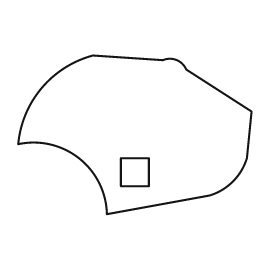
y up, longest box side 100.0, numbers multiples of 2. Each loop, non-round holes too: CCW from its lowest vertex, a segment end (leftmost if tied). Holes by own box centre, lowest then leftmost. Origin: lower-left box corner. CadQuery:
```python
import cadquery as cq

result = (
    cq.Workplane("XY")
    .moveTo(38.0, 0.0)
    .lineTo(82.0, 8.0)
    .threePointArc((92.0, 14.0), (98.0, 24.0))
    .lineTo(100.0, 44.0)
    .lineTo(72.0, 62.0)
    .threePointArc((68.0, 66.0), (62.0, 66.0))
    .lineTo(32.0, 68.0)
    .threePointArc((10.0, 54.0), (0.0, 30.0))
    .threePointArc((26.0, 24.0), (38.0, 0.0))
    .close()
    .moveTo(44.0, 12.0)
    .lineTo(56.0, 12.0)
    .lineTo(56.0, 24.0)
    .lineTo(44.0, 24.0)
    .close()
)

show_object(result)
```